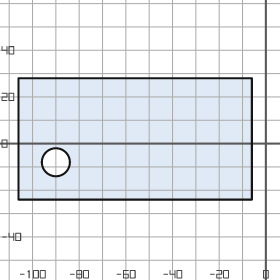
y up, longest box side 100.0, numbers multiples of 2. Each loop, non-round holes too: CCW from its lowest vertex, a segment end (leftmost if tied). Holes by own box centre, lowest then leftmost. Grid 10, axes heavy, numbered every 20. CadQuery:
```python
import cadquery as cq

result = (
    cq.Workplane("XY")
    .moveTo(-106.0, -24.0)
    .lineTo(-6.0, -24.0)
    .lineTo(-6.0, 28.0)
    .lineTo(-106.0, 28.0)
    .close()
    .moveTo(-90.0, -8.0)
    .circle(6.0)
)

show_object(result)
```